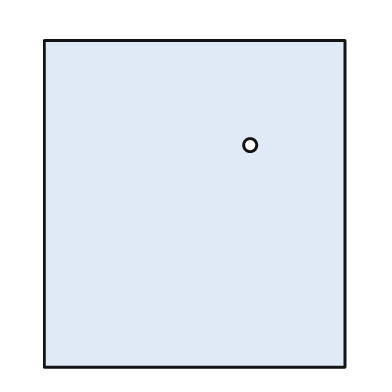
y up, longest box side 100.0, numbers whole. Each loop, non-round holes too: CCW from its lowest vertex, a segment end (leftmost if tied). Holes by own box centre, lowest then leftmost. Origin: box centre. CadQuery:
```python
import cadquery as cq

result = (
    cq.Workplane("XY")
    .moveTo(-46.0, -50.0)
    .lineTo(46.0, -50.0)
    .lineTo(46.0, 50.0)
    .lineTo(-46.0, 50.0)
    .close()
    .moveTo(17.0, 18.0)
    .circle(2.0)
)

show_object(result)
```